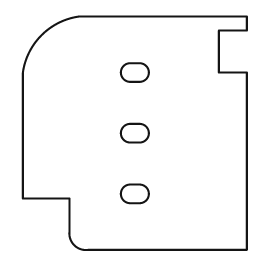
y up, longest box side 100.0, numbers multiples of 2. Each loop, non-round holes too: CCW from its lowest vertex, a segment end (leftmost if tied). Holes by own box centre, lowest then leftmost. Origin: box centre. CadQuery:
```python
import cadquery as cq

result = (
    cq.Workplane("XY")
    .moveTo(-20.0, -50.0)
    .lineTo(48.0, -50.0)
    .lineTo(48.0, 26.0)
    .lineTo(36.0, 26.0)
    .lineTo(36.0, 44.0)
    .lineTo(48.0, 44.0)
    .lineTo(48.0, 50.0)
    .lineTo(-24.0, 50.0)
    .threePointArc((-40.0, 42.0), (-48.0, 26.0))
    .lineTo(-48.0, -28.0)
    .lineTo(-28.0, -28.0)
    .lineTo(-28.0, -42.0)
    .threePointArc((-26.0, -48.0), (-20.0, -50.0))
    .close()
    .moveTo(-2.0, -30.0)
    .lineTo(2.0, -30.0)
    .threePointArc((6.0, -26.0), (2.0, -22.0))
    .lineTo(-2.0, -22.0)
    .threePointArc((-6.0, -26.0), (-2.0, -30.0))
    .close()
    .moveTo(-2.0, -4.0)
    .lineTo(2.0, -4.0)
    .threePointArc((6.0, 0.0), (2.0, 4.0))
    .lineTo(-2.0, 4.0)
    .threePointArc((-6.0, 0.0), (-2.0, -4.0))
    .close()
    .moveTo(-2.0, 22.0)
    .lineTo(2.0, 22.0)
    .threePointArc((6.0, 26.0), (2.0, 30.0))
    .lineTo(-2.0, 30.0)
    .threePointArc((-6.0, 26.0), (-2.0, 22.0))
    .close()
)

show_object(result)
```